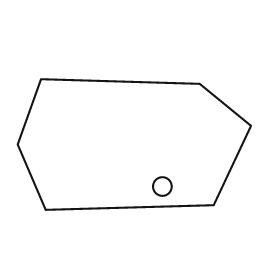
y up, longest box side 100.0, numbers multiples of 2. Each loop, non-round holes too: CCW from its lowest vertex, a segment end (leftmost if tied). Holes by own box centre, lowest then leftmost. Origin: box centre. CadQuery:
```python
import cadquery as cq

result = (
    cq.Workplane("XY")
    .moveTo(-38.0, -28.0)
    .lineTo(34.0, -26.0)
    .lineTo(50.0, 8.0)
    .lineTo(28.0, 26.0)
    .lineTo(-40.0, 28.0)
    .lineTo(-50.0, 0.0)
    .close()
    .moveTo(12.0, -18.0)
    .circle(4.0)
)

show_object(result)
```